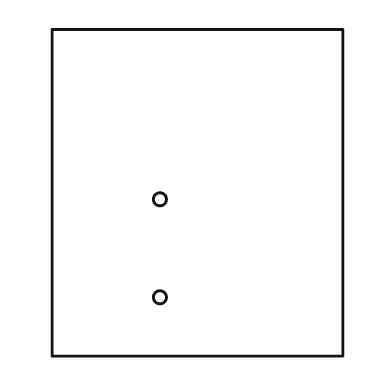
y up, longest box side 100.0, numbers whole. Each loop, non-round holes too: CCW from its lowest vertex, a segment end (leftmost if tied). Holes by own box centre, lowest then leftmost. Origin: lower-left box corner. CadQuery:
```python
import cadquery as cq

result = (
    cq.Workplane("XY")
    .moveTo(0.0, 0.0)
    .lineTo(89.0, 0.0)
    .lineTo(89.0, 100.0)
    .lineTo(0.0, 100.0)
    .close()
    .moveTo(33.0, 18.0)
    .circle(2.0)
    .moveTo(33.0, 48.0)
    .circle(2.0)
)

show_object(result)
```